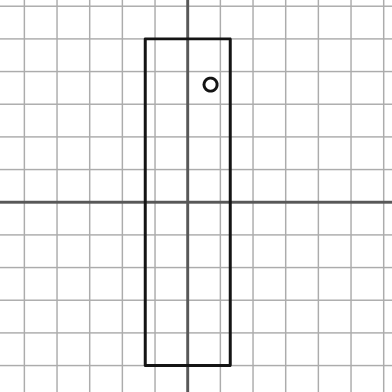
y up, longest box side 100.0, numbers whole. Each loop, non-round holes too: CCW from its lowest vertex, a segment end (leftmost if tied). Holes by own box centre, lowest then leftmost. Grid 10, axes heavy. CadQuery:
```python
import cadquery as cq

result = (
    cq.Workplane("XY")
    .moveTo(-13.0, -50.0)
    .lineTo(13.0, -50.0)
    .lineTo(13.0, 50.0)
    .lineTo(-13.0, 50.0)
    .close()
    .moveTo(7.0, 36.0)
    .circle(2.0)
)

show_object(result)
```